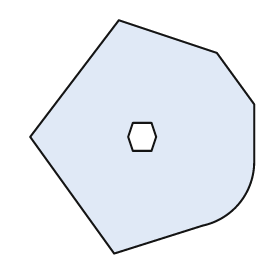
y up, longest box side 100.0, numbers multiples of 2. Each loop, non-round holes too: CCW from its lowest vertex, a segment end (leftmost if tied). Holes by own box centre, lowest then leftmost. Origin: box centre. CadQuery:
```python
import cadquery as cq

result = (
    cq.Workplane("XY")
    .moveTo(-12.0, -50.0)
    .lineTo(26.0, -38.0)
    .threePointArc((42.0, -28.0), (48.0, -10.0))
    .lineTo(48.0, 14.0)
    .lineTo(32.0, 36.0)
    .lineTo(-10.0, 50.0)
    .lineTo(-48.0, 0.0)
    .close()
    .moveTo(-4.0, -6.0)
    .lineTo(4.0, -6.0)
    .lineTo(6.0, 0.0)
    .lineTo(4.0, 6.0)
    .lineTo(-4.0, 6.0)
    .lineTo(-6.0, 0.0)
    .close()
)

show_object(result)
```